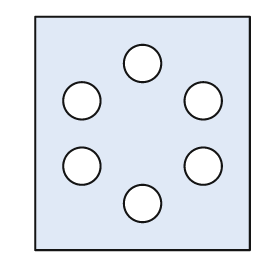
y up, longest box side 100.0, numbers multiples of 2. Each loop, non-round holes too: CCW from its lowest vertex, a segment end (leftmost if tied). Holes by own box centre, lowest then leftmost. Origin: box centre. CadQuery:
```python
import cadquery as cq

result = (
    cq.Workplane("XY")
    .moveTo(-46.0, -50.0)
    .lineTo(46.0, -50.0)
    .lineTo(46.0, 50.0)
    .lineTo(-46.0, 50.0)
    .close()
    .moveTo(0.0, -30.0)
    .circle(8.0)
    .moveTo(-26.0, -14.0)
    .circle(8.0)
    .moveTo(26.0, -14.0)
    .circle(8.0)
    .moveTo(-26.0, 14.0)
    .circle(8.0)
    .moveTo(26.0, 14.0)
    .circle(8.0)
    .moveTo(0.0, 30.0)
    .circle(8.0)
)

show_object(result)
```